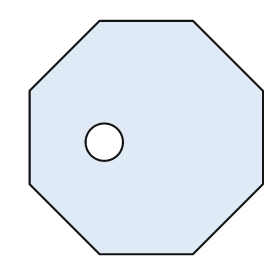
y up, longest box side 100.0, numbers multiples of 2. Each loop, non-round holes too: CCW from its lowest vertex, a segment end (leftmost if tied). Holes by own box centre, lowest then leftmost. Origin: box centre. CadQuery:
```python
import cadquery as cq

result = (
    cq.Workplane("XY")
    .moveTo(-20.0, -50.0)
    .lineTo(20.0, -50.0)
    .lineTo(50.0, -20.0)
    .lineTo(50.0, 20.0)
    .lineTo(20.0, 50.0)
    .lineTo(-20.0, 50.0)
    .lineTo(-50.0, 20.0)
    .lineTo(-50.0, -20.0)
    .close()
    .moveTo(-18.0, -2.0)
    .circle(8.0)
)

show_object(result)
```